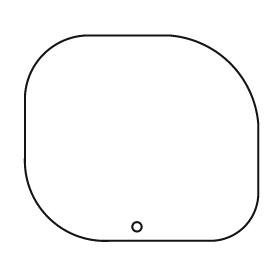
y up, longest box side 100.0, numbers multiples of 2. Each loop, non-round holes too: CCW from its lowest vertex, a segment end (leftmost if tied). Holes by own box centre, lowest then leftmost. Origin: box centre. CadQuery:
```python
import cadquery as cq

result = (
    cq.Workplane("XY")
    .moveTo(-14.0, -44.0)
    .lineTo(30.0, -44.0)
    .threePointArc((44.0, -38.0), (50.0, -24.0))
    .lineTo(50.0, 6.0)
    .threePointArc((38.0, 32.0), (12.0, 44.0))
    .lineTo(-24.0, 44.0)
    .threePointArc((-42.0, 36.0), (-50.0, 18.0))
    .lineTo(-50.0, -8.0)
    .threePointArc((-40.0, -34.0), (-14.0, -44.0))
    .close()
    .moveTo(-2.0, -38.0)
    .circle(2.0)
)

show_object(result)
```